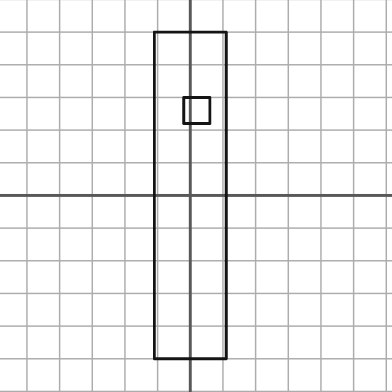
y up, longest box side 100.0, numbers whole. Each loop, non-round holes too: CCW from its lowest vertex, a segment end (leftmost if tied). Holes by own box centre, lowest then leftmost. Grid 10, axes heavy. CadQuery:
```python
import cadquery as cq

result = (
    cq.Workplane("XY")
    .moveTo(-11.0, -50.0)
    .lineTo(11.0, -50.0)
    .lineTo(11.0, 50.0)
    .lineTo(-11.0, 50.0)
    .close()
    .moveTo(-2.0, 22.0)
    .lineTo(6.0, 22.0)
    .lineTo(6.0, 30.0)
    .lineTo(-2.0, 30.0)
    .close()
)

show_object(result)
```